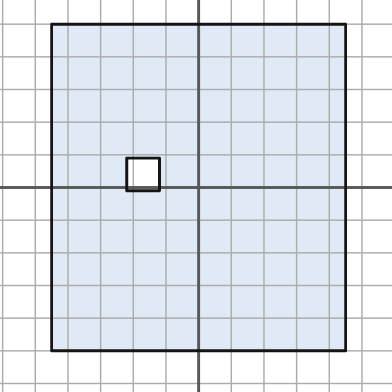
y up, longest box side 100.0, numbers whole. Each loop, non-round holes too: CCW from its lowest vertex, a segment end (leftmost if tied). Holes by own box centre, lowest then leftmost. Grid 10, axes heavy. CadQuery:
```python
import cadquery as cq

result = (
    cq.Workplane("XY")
    .moveTo(-45.0, -50.0)
    .lineTo(45.0, -50.0)
    .lineTo(45.0, 50.0)
    .lineTo(-45.0, 50.0)
    .close()
    .moveTo(-22.0, -1.0)
    .lineTo(-12.0, -1.0)
    .lineTo(-12.0, 9.0)
    .lineTo(-22.0, 9.0)
    .close()
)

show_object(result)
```